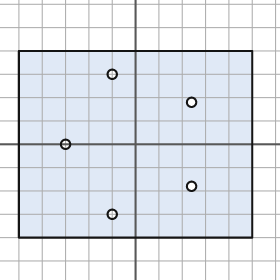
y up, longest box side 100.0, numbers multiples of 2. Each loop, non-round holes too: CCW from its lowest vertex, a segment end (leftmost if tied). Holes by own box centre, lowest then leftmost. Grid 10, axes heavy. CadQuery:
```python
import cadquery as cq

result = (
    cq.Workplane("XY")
    .moveTo(-50.0, -40.0)
    .lineTo(50.0, -40.0)
    .lineTo(50.0, 40.0)
    .lineTo(-50.0, 40.0)
    .close()
    .moveTo(-10.0, -30.0)
    .circle(2.0)
    .moveTo(24.0, -18.0)
    .circle(2.0)
    .moveTo(-30.0, 0.0)
    .circle(2.0)
    .moveTo(24.0, 18.0)
    .circle(2.0)
    .moveTo(-10.0, 30.0)
    .circle(2.0)
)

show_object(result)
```